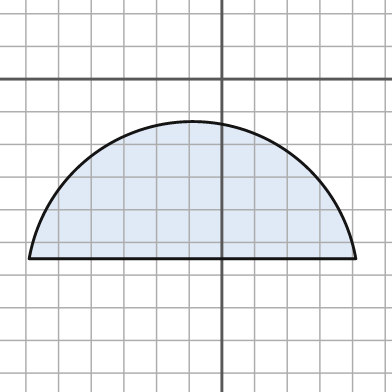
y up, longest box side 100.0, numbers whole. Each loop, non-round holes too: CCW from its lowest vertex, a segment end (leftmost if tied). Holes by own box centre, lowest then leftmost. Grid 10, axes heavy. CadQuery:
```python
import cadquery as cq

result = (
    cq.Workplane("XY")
    .moveTo(-59.0, -55.0)
    .lineTo(41.0, -55.0)
    .threePointArc((-9.0, -13.0), (-59.0, -55.0))
    .close()
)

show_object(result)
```